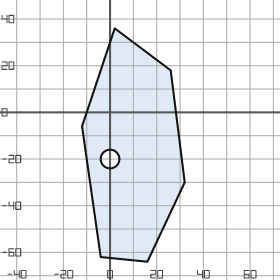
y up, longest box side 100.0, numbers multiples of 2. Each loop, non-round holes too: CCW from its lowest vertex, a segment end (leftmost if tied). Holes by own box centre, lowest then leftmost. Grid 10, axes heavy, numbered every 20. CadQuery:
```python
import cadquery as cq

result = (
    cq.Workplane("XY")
    .moveTo(16.0, -64.0)
    .lineTo(32.0, -30.0)
    .lineTo(26.0, 18.0)
    .lineTo(2.0, 36.0)
    .lineTo(-12.0, -6.0)
    .lineTo(-4.0, -62.0)
    .close()
    .moveTo(0.0, -20.0)
    .circle(4.0)
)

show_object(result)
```